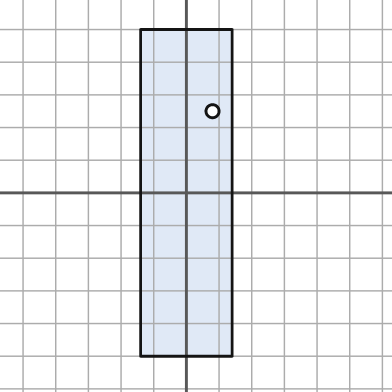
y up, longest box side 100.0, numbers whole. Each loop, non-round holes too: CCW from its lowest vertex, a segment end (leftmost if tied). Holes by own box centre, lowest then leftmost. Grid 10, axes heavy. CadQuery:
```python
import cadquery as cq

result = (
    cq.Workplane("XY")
    .moveTo(-14.0, -50.0)
    .lineTo(14.0, -50.0)
    .lineTo(14.0, 50.0)
    .lineTo(-14.0, 50.0)
    .close()
    .moveTo(8.0, 25.0)
    .circle(2.0)
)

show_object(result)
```